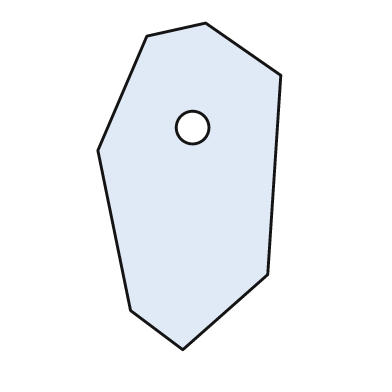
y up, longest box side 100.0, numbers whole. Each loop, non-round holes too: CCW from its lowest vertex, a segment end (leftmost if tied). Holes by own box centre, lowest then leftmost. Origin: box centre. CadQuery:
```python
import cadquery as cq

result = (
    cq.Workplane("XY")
    .moveTo(-2.0, -50.0)
    .lineTo(24.0, -27.0)
    .lineTo(28.0, 34.0)
    .lineTo(5.0, 50.0)
    .lineTo(-13.0, 46.0)
    .lineTo(-28.0, 11.0)
    .lineTo(-18.0, -38.0)
    .close()
    .moveTo(1.0, 18.0)
    .circle(5.0)
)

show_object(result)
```